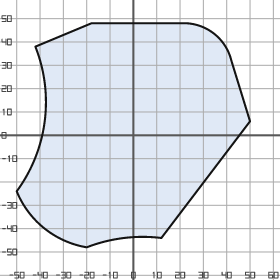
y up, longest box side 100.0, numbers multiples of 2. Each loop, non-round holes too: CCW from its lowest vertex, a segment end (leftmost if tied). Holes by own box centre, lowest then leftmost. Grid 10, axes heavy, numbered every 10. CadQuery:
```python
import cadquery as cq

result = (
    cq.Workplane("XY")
    .moveTo(-20.0, -48.0)
    .threePointArc((-4.0, -44.0), (12.0, -44.0))
    .lineTo(50.0, 6.0)
    .lineTo(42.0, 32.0)
    .threePointArc((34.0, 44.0), (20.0, 48.0))
    .lineTo(-18.0, 48.0)
    .lineTo(-42.0, 38.0)
    .threePointArc((-38.0, 6.0), (-50.0, -24.0))
    .threePointArc((-38.0, -40.0), (-20.0, -48.0))
    .close()
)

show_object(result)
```